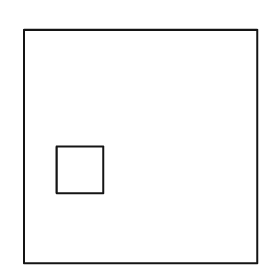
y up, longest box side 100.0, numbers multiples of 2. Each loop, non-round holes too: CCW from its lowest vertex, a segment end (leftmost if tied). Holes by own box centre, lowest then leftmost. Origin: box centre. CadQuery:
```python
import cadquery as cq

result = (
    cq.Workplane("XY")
    .moveTo(-50.0, -50.0)
    .lineTo(50.0, -50.0)
    .lineTo(50.0, 50.0)
    .lineTo(-50.0, 50.0)
    .close()
    .moveTo(-36.0, -20.0)
    .lineTo(-16.0, -20.0)
    .lineTo(-16.0, 0.0)
    .lineTo(-36.0, 0.0)
    .close()
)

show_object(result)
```